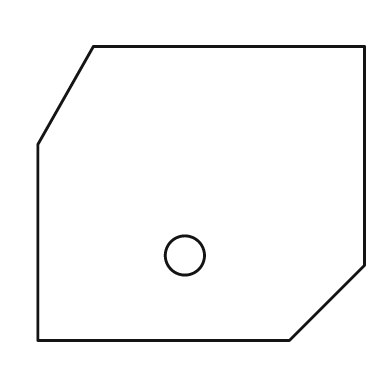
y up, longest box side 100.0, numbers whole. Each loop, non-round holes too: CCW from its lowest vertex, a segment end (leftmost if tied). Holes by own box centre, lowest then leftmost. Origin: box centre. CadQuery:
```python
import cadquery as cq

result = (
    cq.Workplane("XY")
    .moveTo(-50.0, -45.0)
    .lineTo(27.0, -45.0)
    .lineTo(50.0, -22.0)
    .lineTo(50.0, 45.0)
    .lineTo(-33.0, 45.0)
    .lineTo(-50.0, 15.0)
    .close()
    .moveTo(-5.0, -19.0)
    .circle(6.0)
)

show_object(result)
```